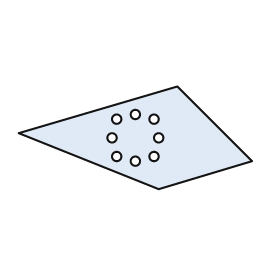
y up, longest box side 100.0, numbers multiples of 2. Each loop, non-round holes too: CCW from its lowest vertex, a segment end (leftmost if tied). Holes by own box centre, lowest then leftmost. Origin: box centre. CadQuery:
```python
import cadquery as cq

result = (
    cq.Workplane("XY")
    .moveTo(10.0, -22.0)
    .lineTo(50.0, -10.0)
    .lineTo(18.0, 22.0)
    .lineTo(-50.0, 2.0)
    .close()
    .moveTo(0.0, -10.0)
    .circle(2.0)
    .moveTo(-8.0, -8.0)
    .circle(2.0)
    .moveTo(8.0, -8.0)
    .circle(2.0)
    .moveTo(-10.0, 0.0)
    .circle(2.0)
    .moveTo(10.0, 0.0)
    .circle(2.0)
    .moveTo(-8.0, 8.0)
    .circle(2.0)
    .moveTo(8.0, 8.0)
    .circle(2.0)
    .moveTo(0.0, 10.0)
    .circle(2.0)
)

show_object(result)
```